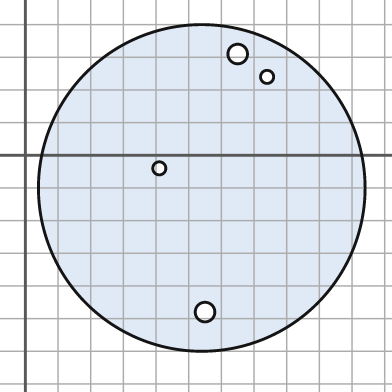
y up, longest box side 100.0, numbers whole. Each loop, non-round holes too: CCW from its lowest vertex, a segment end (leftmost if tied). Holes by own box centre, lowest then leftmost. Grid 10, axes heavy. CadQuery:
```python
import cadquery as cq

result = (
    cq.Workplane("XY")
    .moveTo(54.0, -10.0)
    .circle(50.0)
    .moveTo(55.0, -48.0)
    .circle(3.0)
    .moveTo(41.0, -4.0)
    .circle(2.0)
    .moveTo(74.0, 24.0)
    .circle(2.0)
    .moveTo(65.0, 31.0)
    .circle(3.0)
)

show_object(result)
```